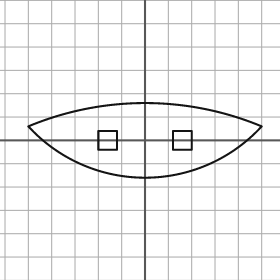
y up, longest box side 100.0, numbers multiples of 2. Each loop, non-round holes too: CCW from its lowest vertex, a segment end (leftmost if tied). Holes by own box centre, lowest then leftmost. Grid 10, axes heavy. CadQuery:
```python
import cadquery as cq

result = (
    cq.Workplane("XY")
    .moveTo(-50.0, 6.0)
    .threePointArc((0.0, -16.0), (50.0, 6.0))
    .threePointArc((0.0, 16.0), (-50.0, 6.0))
    .close()
    .moveTo(-20.0, -4.0)
    .lineTo(-12.0, -4.0)
    .lineTo(-12.0, 4.0)
    .lineTo(-20.0, 4.0)
    .close()
    .moveTo(12.0, -4.0)
    .lineTo(20.0, -4.0)
    .lineTo(20.0, 4.0)
    .lineTo(12.0, 4.0)
    .close()
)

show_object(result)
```